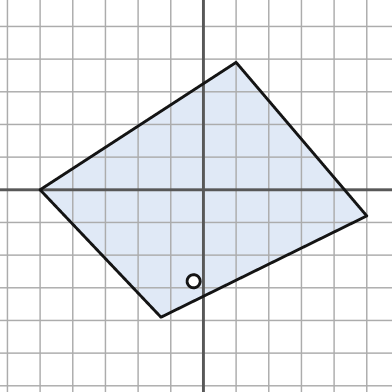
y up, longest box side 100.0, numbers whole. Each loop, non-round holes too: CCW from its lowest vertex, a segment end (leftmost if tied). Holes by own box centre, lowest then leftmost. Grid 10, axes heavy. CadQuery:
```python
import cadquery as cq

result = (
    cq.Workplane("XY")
    .moveTo(-13.0, -39.0)
    .lineTo(50.0, -8.0)
    .lineTo(10.0, 39.0)
    .lineTo(-50.0, 0.0)
    .close()
    .moveTo(-3.0, -28.0)
    .circle(2.0)
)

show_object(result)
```